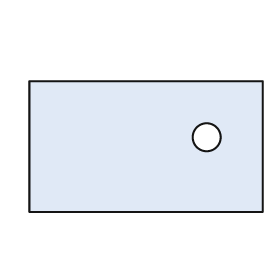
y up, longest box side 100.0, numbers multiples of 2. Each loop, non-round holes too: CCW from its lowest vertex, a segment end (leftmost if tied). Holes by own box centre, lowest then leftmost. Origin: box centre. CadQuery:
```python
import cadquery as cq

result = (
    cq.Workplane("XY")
    .moveTo(-50.0, -28.0)
    .lineTo(50.0, -28.0)
    .lineTo(50.0, 28.0)
    .lineTo(-50.0, 28.0)
    .close()
    .moveTo(26.0, 4.0)
    .circle(6.0)
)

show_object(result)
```